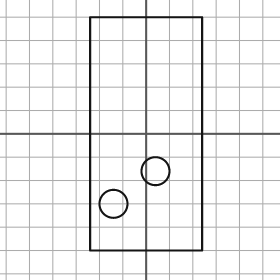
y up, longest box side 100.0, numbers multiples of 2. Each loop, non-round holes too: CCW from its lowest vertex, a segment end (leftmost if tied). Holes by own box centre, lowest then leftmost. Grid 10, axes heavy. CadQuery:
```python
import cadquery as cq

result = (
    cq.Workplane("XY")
    .moveTo(-24.0, -50.0)
    .lineTo(24.0, -50.0)
    .lineTo(24.0, 50.0)
    .lineTo(-24.0, 50.0)
    .close()
    .moveTo(-14.0, -30.0)
    .circle(6.0)
    .moveTo(4.0, -16.0)
    .circle(6.0)
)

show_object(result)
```